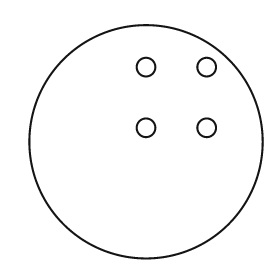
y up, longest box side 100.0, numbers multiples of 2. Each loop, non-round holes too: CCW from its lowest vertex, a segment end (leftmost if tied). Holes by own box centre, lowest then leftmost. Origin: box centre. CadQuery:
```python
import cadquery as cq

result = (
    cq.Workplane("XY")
    .moveTo(0.0, 0.0)
    .circle(50.0)
    .moveTo(0.0, 6.0)
    .circle(4.0)
    .moveTo(26.0, 6.0)
    .circle(4.0)
    .moveTo(0.0, 32.0)
    .circle(4.0)
    .moveTo(26.0, 32.0)
    .circle(4.0)
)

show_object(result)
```